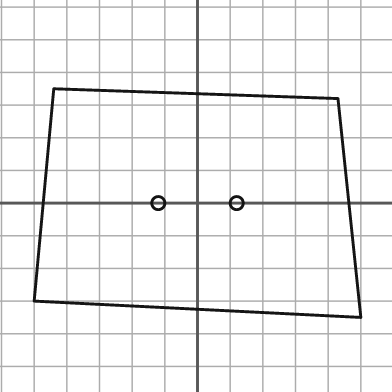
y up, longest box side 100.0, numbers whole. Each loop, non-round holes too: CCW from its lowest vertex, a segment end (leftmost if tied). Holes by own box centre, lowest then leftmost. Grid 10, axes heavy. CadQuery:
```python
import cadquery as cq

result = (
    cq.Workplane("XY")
    .moveTo(50.0, -35.0)
    .lineTo(43.0, 32.0)
    .lineTo(-44.0, 35.0)
    .lineTo(-50.0, -30.0)
    .close()
    .moveTo(-12.0, 0.0)
    .circle(2.0)
    .moveTo(12.0, 0.0)
    .circle(2.0)
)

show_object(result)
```